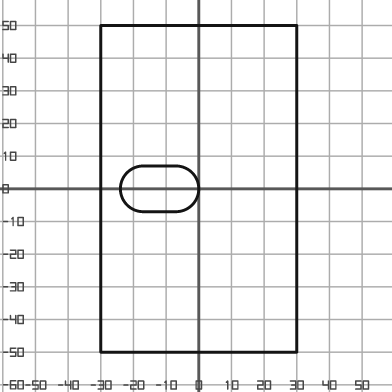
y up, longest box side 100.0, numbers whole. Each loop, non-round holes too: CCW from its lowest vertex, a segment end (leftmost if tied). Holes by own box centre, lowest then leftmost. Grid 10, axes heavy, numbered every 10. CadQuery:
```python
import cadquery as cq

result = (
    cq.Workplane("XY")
    .moveTo(-30.0, -50.0)
    .lineTo(30.0, -50.0)
    .lineTo(30.0, 50.0)
    .lineTo(-30.0, 50.0)
    .close()
    .moveTo(-17.0, -7.0)
    .lineTo(-7.0, -7.0)
    .threePointArc((0.0, 0.0), (-7.0, 7.0))
    .lineTo(-17.0, 7.0)
    .threePointArc((-24.0, 0.0), (-17.0, -7.0))
    .close()
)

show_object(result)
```